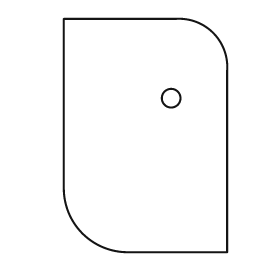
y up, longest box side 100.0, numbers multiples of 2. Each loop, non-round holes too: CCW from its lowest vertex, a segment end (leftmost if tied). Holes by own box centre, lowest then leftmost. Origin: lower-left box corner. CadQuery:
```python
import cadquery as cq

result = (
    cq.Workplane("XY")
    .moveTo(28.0, 0.0)
    .lineTo(70.0, 0.0)
    .lineTo(70.0, 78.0)
    .threePointArc((64.0, 94.0), (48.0, 100.0))
    .lineTo(0.0, 100.0)
    .lineTo(0.0, 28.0)
    .threePointArc((8.0, 8.0), (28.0, 0.0))
    .close()
    .moveTo(46.0, 66.0)
    .circle(4.0)
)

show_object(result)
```